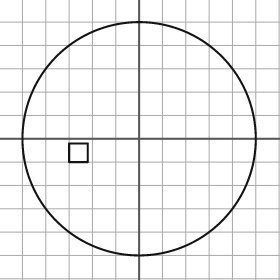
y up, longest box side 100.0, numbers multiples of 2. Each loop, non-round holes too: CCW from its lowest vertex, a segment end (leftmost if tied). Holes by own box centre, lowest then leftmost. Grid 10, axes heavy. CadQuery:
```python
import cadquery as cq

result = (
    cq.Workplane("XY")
    .moveTo(0.0, 0.0)
    .circle(50.0)
    .moveTo(-30.0, -10.0)
    .lineTo(-22.0, -10.0)
    .lineTo(-22.0, -2.0)
    .lineTo(-30.0, -2.0)
    .close()
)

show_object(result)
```